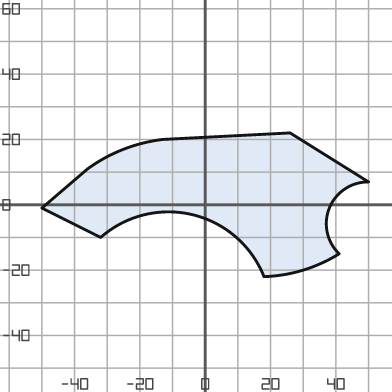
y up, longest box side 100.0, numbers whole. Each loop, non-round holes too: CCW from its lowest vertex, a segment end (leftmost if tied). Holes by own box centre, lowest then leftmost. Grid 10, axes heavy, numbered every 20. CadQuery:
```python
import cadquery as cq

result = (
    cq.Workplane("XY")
    .moveTo(18.0, -22.0)
    .threePointArc((30.0, -20.0), (41.0, -15.0))
    .threePointArc((38.0, -1.0), (50.0, 7.0))
    .lineTo(26.0, 22.0)
    .lineTo(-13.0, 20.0)
    .threePointArc((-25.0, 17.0), (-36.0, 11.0))
    .lineTo(-50.0, -1.0)
    .lineTo(-32.0, -10.0)
    .threePointArc((-4.0, -3.0), (18.0, -22.0))
    .close()
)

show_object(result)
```